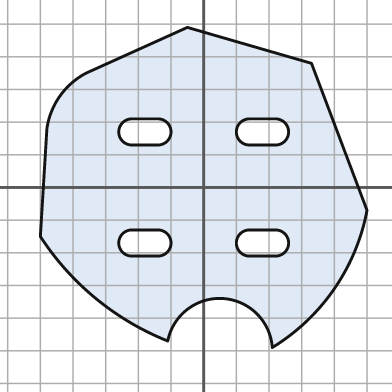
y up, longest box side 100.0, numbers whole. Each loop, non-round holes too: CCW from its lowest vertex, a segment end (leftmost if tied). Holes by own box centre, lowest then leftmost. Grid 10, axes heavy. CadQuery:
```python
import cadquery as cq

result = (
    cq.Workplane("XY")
    .moveTo(21.0, -49.0)
    .threePointArc((40.0, -31.0), (50.0, -7.0))
    .lineTo(33.0, 38.0)
    .lineTo(-5.0, 49.0)
    .lineTo(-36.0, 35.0)
    .threePointArc((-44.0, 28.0), (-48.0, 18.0))
    .lineTo(-50.0, -15.0)
    .threePointArc((-33.0, -34.0), (-11.0, -47.0))
    .threePointArc((6.0, -34.0), (21.0, -49.0))
    .close()
    .moveTo(-22.0, -21.0)
    .lineTo(-14.0, -21.0)
    .threePointArc((-10.0, -17.0), (-14.0, -13.0))
    .lineTo(-22.0, -13.0)
    .threePointArc((-26.0, -17.0), (-22.0, -21.0))
    .close()
    .moveTo(14.0, -21.0)
    .lineTo(22.0, -21.0)
    .threePointArc((26.0, -17.0), (22.0, -13.0))
    .lineTo(14.0, -13.0)
    .threePointArc((10.0, -17.0), (14.0, -21.0))
    .close()
    .moveTo(-22.0, 13.0)
    .lineTo(-14.0, 13.0)
    .threePointArc((-10.0, 17.0), (-14.0, 21.0))
    .lineTo(-22.0, 21.0)
    .threePointArc((-26.0, 17.0), (-22.0, 13.0))
    .close()
    .moveTo(14.0, 13.0)
    .lineTo(22.0, 13.0)
    .threePointArc((26.0, 17.0), (22.0, 21.0))
    .lineTo(14.0, 21.0)
    .threePointArc((10.0, 17.0), (14.0, 13.0))
    .close()
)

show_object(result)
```